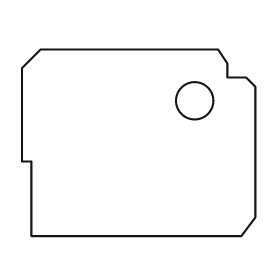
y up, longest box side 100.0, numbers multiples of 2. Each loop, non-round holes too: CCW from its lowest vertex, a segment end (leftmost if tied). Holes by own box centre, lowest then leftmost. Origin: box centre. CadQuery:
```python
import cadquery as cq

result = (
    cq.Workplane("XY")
    .moveTo(-46.0, -40.0)
    .lineTo(44.0, -40.0)
    .lineTo(50.0, -32.0)
    .lineTo(50.0, 24.0)
    .lineTo(46.0, 28.0)
    .lineTo(38.0, 28.0)
    .lineTo(38.0, 34.0)
    .lineTo(34.0, 40.0)
    .lineTo(-42.0, 40.0)
    .lineTo(-50.0, 32.0)
    .lineTo(-50.0, -8.0)
    .lineTo(-46.0, -8.0)
    .close()
    .moveTo(24.0, 18.0)
    .circle(8.0)
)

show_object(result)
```